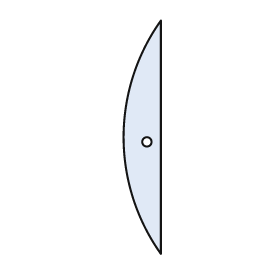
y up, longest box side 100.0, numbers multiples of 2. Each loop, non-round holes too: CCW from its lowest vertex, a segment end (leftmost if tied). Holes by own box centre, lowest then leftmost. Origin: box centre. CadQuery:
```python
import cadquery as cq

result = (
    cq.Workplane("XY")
    .moveTo(8.0, -50.0)
    .lineTo(8.0, 50.0)
    .threePointArc((-8.0, 0.0), (8.0, -50.0))
    .close()
    .moveTo(2.0, -2.0)
    .circle(2.0)
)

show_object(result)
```